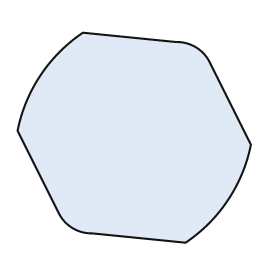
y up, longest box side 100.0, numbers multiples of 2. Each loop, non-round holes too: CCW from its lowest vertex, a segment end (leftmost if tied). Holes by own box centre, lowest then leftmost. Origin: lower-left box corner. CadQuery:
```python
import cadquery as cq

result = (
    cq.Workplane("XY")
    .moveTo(72.0, 0.0)
    .threePointArc((90.0, 18.0), (100.0, 42.0))
    .lineTo(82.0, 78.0)
    .threePointArc((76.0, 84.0), (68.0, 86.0))
    .lineTo(28.0, 90.0)
    .threePointArc((10.0, 72.0), (0.0, 48.0))
    .lineTo(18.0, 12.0)
    .threePointArc((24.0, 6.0), (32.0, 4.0))
    .close()
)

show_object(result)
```